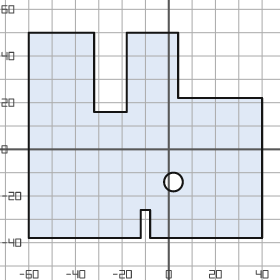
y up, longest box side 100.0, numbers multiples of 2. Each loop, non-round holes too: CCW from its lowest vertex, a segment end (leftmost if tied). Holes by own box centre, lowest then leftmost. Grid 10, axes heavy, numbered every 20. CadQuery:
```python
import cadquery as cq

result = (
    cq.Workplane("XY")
    .moveTo(-60.0, -38.0)
    .lineTo(-12.0, -38.0)
    .lineTo(-12.0, -26.0)
    .lineTo(-8.0, -26.0)
    .lineTo(-8.0, -38.0)
    .lineTo(40.0, -38.0)
    .lineTo(40.0, 22.0)
    .lineTo(4.0, 22.0)
    .lineTo(4.0, 50.0)
    .lineTo(-18.0, 50.0)
    .lineTo(-18.0, 16.0)
    .lineTo(-32.0, 16.0)
    .lineTo(-32.0, 50.0)
    .lineTo(-60.0, 50.0)
    .close()
    .moveTo(2.0, -14.0)
    .circle(4.0)
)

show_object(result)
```